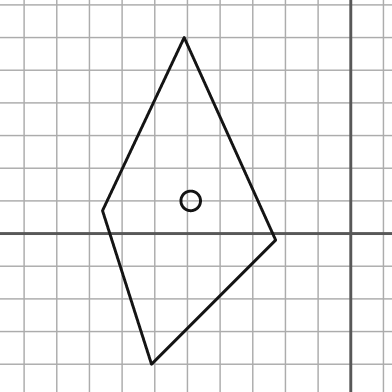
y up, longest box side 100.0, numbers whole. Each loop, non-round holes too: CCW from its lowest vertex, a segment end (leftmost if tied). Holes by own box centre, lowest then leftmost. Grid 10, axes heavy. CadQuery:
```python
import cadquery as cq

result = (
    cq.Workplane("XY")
    .moveTo(-61.0, -40.0)
    .lineTo(-23.0, -2.0)
    .lineTo(-51.0, 60.0)
    .lineTo(-76.0, 7.0)
    .close()
    .moveTo(-49.0, 10.0)
    .circle(3.0)
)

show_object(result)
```